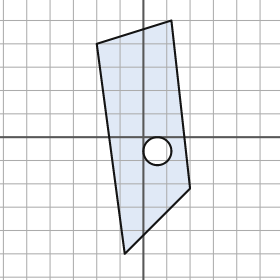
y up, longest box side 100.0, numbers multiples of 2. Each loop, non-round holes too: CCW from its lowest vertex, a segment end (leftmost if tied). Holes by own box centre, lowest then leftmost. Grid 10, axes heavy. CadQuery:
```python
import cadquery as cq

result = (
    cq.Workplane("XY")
    .moveTo(-8.0, -50.0)
    .lineTo(20.0, -22.0)
    .lineTo(12.0, 50.0)
    .lineTo(-20.0, 40.0)
    .close()
    .moveTo(6.0, -6.0)
    .circle(6.0)
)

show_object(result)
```